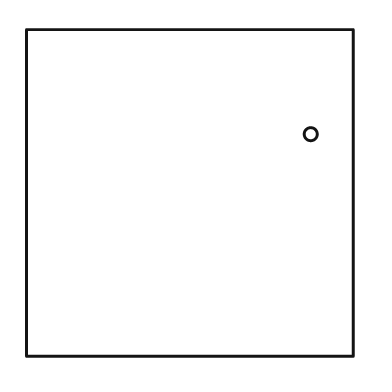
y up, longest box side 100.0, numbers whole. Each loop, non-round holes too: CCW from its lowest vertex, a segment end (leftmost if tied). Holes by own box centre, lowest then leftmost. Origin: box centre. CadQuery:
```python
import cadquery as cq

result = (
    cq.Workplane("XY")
    .moveTo(-50.0, -50.0)
    .lineTo(50.0, -50.0)
    .lineTo(50.0, 50.0)
    .lineTo(-50.0, 50.0)
    .close()
    .moveTo(37.0, 18.0)
    .circle(2.0)
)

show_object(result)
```